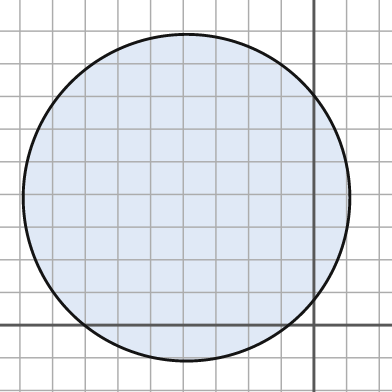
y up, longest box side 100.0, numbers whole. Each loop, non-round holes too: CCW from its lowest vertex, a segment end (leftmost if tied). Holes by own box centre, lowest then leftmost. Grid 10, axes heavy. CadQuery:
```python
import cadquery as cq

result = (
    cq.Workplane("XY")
    .moveTo(-39.0, 39.0)
    .circle(50.0)
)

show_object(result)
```